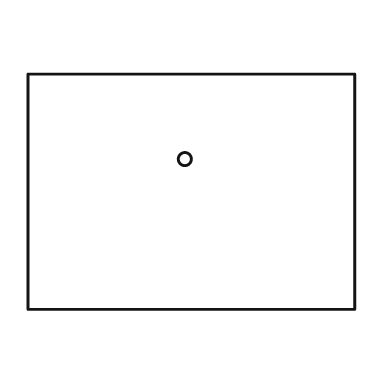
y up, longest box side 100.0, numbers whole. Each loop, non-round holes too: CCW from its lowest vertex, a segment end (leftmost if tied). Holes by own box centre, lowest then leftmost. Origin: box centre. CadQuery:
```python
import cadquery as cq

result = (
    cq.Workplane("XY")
    .moveTo(-50.0, -36.0)
    .lineTo(50.0, -36.0)
    .lineTo(50.0, 36.0)
    .lineTo(-50.0, 36.0)
    .close()
    .moveTo(-2.0, 10.0)
    .circle(2.0)
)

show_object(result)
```